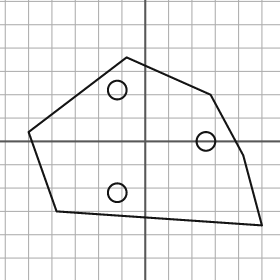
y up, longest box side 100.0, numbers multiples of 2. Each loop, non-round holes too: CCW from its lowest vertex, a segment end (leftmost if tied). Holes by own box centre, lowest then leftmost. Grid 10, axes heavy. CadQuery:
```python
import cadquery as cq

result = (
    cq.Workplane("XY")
    .moveTo(50.0, -36.0)
    .lineTo(42.0, -6.0)
    .lineTo(28.0, 20.0)
    .lineTo(-8.0, 36.0)
    .lineTo(-50.0, 4.0)
    .lineTo(-38.0, -30.0)
    .close()
    .moveTo(-12.0, -22.0)
    .circle(4.0)
    .moveTo(26.0, 0.0)
    .circle(4.0)
    .moveTo(-12.0, 22.0)
    .circle(4.0)
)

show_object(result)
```